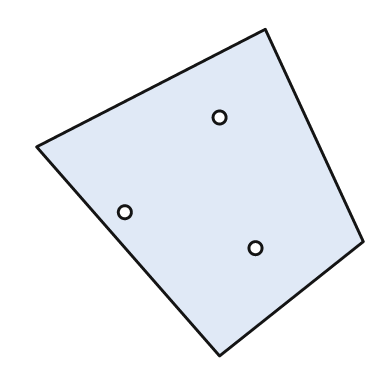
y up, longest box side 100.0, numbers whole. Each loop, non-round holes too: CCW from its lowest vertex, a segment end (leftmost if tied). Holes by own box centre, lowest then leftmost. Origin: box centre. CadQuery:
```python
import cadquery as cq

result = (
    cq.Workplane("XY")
    .moveTo(6.0, -50.0)
    .lineTo(50.0, -15.0)
    .lineTo(20.0, 50.0)
    .lineTo(-50.0, 14.0)
    .close()
    .moveTo(17.0, -17.0)
    .circle(2.0)
    .moveTo(-23.0, -6.0)
    .circle(2.0)
    .moveTo(6.0, 23.0)
    .circle(2.0)
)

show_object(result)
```